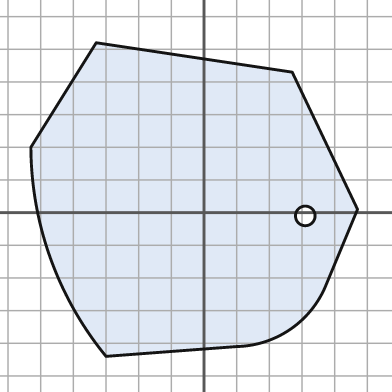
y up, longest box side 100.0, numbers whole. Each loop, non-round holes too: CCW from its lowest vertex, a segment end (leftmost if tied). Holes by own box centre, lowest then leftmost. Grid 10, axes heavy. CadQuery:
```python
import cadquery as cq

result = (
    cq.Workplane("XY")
    .moveTo(-30.0, -44.0)
    .lineTo(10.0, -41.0)
    .threePointArc((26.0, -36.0), (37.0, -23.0))
    .lineTo(47.0, 1.0)
    .lineTo(27.0, 43.0)
    .lineTo(-33.0, 52.0)
    .lineTo(-53.0, 20.0)
    .threePointArc((-47.0, -14.0), (-30.0, -44.0))
    .close()
    .moveTo(31.0, -1.0)
    .circle(3.0)
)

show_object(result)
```